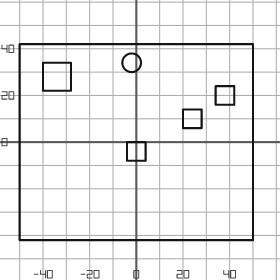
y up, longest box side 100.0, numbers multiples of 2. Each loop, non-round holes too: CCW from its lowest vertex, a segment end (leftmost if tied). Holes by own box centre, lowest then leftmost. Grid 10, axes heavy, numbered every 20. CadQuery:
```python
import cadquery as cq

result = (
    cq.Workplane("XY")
    .moveTo(-50.0, -42.0)
    .lineTo(50.0, -42.0)
    .lineTo(50.0, 42.0)
    .lineTo(-50.0, 42.0)
    .close()
    .moveTo(-4.0, -8.0)
    .lineTo(4.0, -8.0)
    .lineTo(4.0, 0.0)
    .lineTo(-4.0, 0.0)
    .close()
    .moveTo(20.0, 6.0)
    .lineTo(28.0, 6.0)
    .lineTo(28.0, 14.0)
    .lineTo(20.0, 14.0)
    .close()
    .moveTo(34.0, 16.0)
    .lineTo(42.0, 16.0)
    .lineTo(42.0, 24.0)
    .lineTo(34.0, 24.0)
    .close()
    .moveTo(-40.0, 22.0)
    .lineTo(-28.0, 22.0)
    .lineTo(-28.0, 34.0)
    .lineTo(-40.0, 34.0)
    .close()
    .moveTo(-2.0, 34.0)
    .circle(4.0)
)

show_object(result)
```